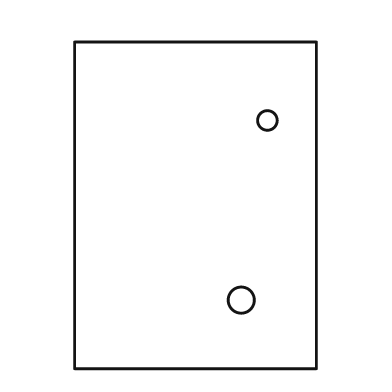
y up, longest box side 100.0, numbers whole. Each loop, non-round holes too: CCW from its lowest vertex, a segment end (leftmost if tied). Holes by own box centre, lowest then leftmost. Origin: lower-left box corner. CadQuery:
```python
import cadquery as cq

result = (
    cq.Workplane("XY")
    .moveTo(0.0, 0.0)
    .lineTo(74.0, 0.0)
    .lineTo(74.0, 100.0)
    .lineTo(0.0, 100.0)
    .close()
    .moveTo(51.0, 21.0)
    .circle(4.0)
    .moveTo(59.0, 76.0)
    .circle(3.0)
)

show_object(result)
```